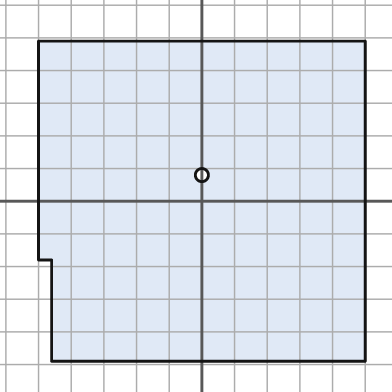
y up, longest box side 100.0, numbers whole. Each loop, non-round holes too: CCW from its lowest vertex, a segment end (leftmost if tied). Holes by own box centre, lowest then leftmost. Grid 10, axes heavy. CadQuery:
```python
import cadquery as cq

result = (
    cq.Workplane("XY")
    .moveTo(-46.0, -49.0)
    .lineTo(50.0, -49.0)
    .lineTo(50.0, 49.0)
    .lineTo(-50.0, 49.0)
    .lineTo(-50.0, -18.0)
    .lineTo(-46.0, -18.0)
    .close()
    .moveTo(0.0, 8.0)
    .circle(2.0)
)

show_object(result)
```